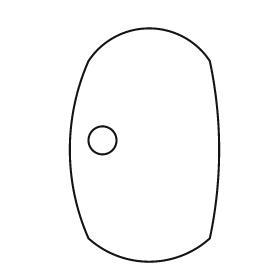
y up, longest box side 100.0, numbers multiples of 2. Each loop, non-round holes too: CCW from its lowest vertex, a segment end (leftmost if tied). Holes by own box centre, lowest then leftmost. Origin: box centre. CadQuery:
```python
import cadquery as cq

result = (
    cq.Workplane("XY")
    .moveTo(-24.0, -40.0)
    .threePointArc((2.0, -50.0), (28.0, -40.0))
    .threePointArc((32.0, -2.0), (28.0, 36.0))
    .threePointArc((2.0, 50.0), (-24.0, 36.0))
    .threePointArc((-32.0, -2.0), (-24.0, -40.0))
    .close()
    .moveTo(-18.0, 2.0)
    .circle(6.0)
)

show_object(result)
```